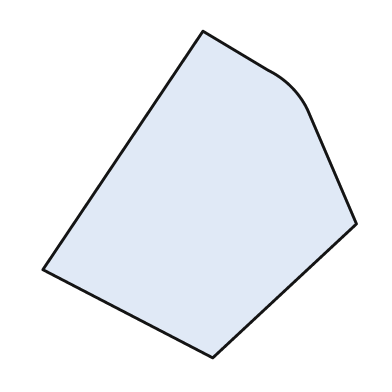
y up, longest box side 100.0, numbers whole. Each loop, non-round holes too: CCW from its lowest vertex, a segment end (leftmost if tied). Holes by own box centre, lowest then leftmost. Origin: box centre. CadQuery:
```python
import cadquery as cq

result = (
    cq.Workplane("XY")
    .moveTo(4.0, -50.0)
    .lineTo(48.0, -9.0)
    .lineTo(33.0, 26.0)
    .threePointArc((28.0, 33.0), (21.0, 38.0))
    .lineTo(1.0, 50.0)
    .lineTo(-48.0, -23.0)
    .close()
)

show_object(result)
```